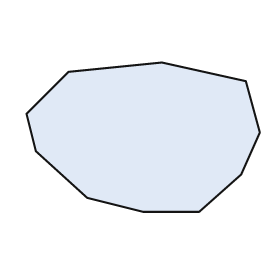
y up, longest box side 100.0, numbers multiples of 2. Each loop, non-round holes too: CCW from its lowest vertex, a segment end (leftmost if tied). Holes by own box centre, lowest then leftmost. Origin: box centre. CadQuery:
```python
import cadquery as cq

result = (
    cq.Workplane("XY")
    .moveTo(0.0, -32.0)
    .lineTo(24.0, -32.0)
    .lineTo(42.0, -16.0)
    .lineTo(50.0, 2.0)
    .lineTo(44.0, 24.0)
    .lineTo(8.0, 32.0)
    .lineTo(-32.0, 28.0)
    .lineTo(-50.0, 10.0)
    .lineTo(-46.0, -6.0)
    .lineTo(-24.0, -26.0)
    .close()
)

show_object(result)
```